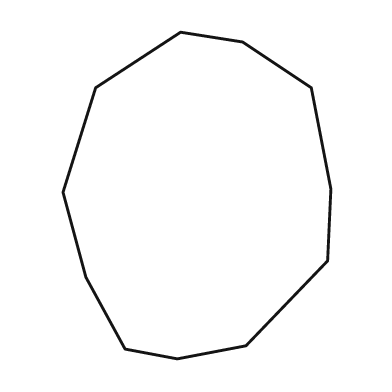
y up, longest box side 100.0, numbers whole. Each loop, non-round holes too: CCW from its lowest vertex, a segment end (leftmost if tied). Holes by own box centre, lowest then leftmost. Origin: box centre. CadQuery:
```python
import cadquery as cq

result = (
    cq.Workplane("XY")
    .moveTo(-6.0, -50.0)
    .lineTo(15.0, -46.0)
    .lineTo(40.0, -20.0)
    .lineTo(41.0, 2.0)
    .lineTo(35.0, 33.0)
    .lineTo(14.0, 47.0)
    .lineTo(-5.0, 50.0)
    .lineTo(-31.0, 33.0)
    .lineTo(-41.0, 1.0)
    .lineTo(-34.0, -25.0)
    .lineTo(-22.0, -47.0)
    .close()
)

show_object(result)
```